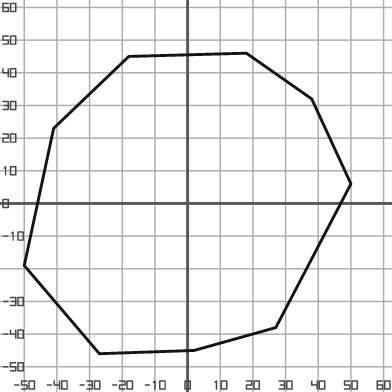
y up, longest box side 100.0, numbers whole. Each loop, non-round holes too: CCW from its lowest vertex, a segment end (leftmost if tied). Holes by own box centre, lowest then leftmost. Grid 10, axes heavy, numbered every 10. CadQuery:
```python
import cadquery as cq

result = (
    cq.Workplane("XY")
    .moveTo(-27.0, -46.0)
    .lineTo(2.0, -45.0)
    .lineTo(27.0, -38.0)
    .lineTo(50.0, 6.0)
    .lineTo(38.0, 32.0)
    .lineTo(18.0, 46.0)
    .lineTo(-18.0, 45.0)
    .lineTo(-41.0, 23.0)
    .lineTo(-50.0, -19.0)
    .close()
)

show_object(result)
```